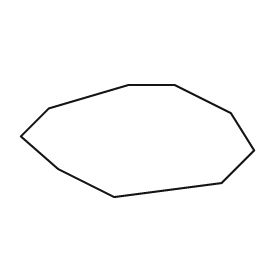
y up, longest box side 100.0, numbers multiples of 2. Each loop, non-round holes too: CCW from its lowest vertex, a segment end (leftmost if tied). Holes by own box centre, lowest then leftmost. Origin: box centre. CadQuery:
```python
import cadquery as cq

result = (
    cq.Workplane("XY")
    .moveTo(-10.0, -24.0)
    .lineTo(36.0, -18.0)
    .lineTo(50.0, -4.0)
    .lineTo(40.0, 12.0)
    .lineTo(16.0, 24.0)
    .lineTo(-4.0, 24.0)
    .lineTo(-38.0, 14.0)
    .lineTo(-50.0, 2.0)
    .lineTo(-34.0, -12.0)
    .close()
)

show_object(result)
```